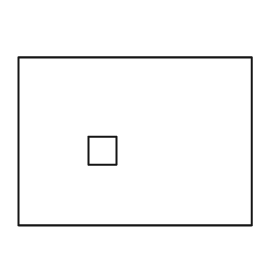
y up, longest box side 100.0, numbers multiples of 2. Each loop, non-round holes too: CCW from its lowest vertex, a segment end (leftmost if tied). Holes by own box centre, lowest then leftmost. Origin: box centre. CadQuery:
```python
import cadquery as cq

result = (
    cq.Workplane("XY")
    .moveTo(-50.0, -36.0)
    .lineTo(50.0, -36.0)
    .lineTo(50.0, 36.0)
    .lineTo(-50.0, 36.0)
    .close()
    .moveTo(-20.0, -10.0)
    .lineTo(-8.0, -10.0)
    .lineTo(-8.0, 2.0)
    .lineTo(-20.0, 2.0)
    .close()
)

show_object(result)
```